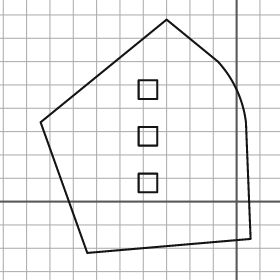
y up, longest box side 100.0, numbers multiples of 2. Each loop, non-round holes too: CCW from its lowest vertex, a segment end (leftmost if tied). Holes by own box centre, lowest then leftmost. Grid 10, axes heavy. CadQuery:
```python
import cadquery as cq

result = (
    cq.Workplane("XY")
    .moveTo(-64.0, -22.0)
    .lineTo(6.0, -16.0)
    .lineTo(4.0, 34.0)
    .threePointArc((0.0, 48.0), (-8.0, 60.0))
    .lineTo(-30.0, 78.0)
    .lineTo(-84.0, 34.0)
    .close()
    .moveTo(-42.0, 4.0)
    .lineTo(-34.0, 4.0)
    .lineTo(-34.0, 12.0)
    .lineTo(-42.0, 12.0)
    .close()
    .moveTo(-42.0, 24.0)
    .lineTo(-34.0, 24.0)
    .lineTo(-34.0, 32.0)
    .lineTo(-42.0, 32.0)
    .close()
    .moveTo(-42.0, 44.0)
    .lineTo(-34.0, 44.0)
    .lineTo(-34.0, 52.0)
    .lineTo(-42.0, 52.0)
    .close()
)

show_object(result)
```